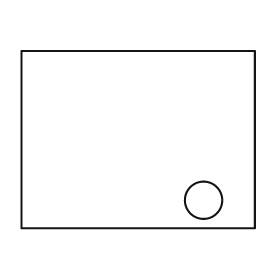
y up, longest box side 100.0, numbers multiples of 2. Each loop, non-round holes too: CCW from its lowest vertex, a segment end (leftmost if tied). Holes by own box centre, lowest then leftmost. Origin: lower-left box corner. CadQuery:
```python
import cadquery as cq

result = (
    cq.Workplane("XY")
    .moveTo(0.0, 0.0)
    .lineTo(100.0, 0.0)
    .lineTo(100.0, 76.0)
    .lineTo(0.0, 76.0)
    .close()
    .moveTo(78.0, 12.0)
    .circle(8.0)
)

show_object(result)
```